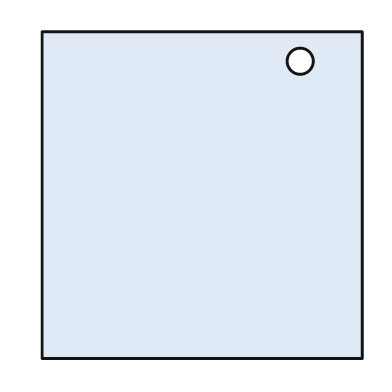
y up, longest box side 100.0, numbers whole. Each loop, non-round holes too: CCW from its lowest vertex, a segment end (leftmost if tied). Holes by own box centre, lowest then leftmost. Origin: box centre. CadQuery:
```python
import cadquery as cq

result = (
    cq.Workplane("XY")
    .moveTo(-49.0, -50.0)
    .lineTo(49.0, -50.0)
    .lineTo(49.0, 50.0)
    .lineTo(-49.0, 50.0)
    .close()
    .moveTo(30.0, 41.0)
    .circle(4.0)
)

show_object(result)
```